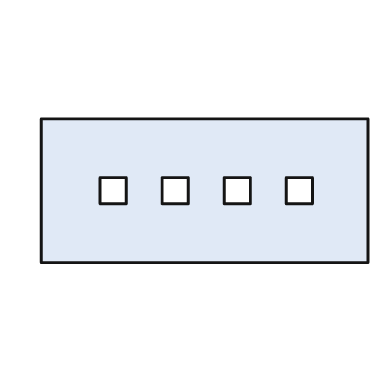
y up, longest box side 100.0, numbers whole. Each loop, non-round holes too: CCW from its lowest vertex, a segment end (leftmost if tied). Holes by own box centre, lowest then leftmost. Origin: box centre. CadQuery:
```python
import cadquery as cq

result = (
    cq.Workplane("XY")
    .moveTo(-50.0, -22.0)
    .lineTo(50.0, -22.0)
    .lineTo(50.0, 22.0)
    .lineTo(-50.0, 22.0)
    .close()
    .moveTo(-32.0, -4.0)
    .lineTo(-24.0, -4.0)
    .lineTo(-24.0, 4.0)
    .lineTo(-32.0, 4.0)
    .close()
    .moveTo(-13.0, -4.0)
    .lineTo(-5.0, -4.0)
    .lineTo(-5.0, 4.0)
    .lineTo(-13.0, 4.0)
    .close()
    .moveTo(6.0, -4.0)
    .lineTo(14.0, -4.0)
    .lineTo(14.0, 4.0)
    .lineTo(6.0, 4.0)
    .close()
    .moveTo(25.0, -4.0)
    .lineTo(33.0, -4.0)
    .lineTo(33.0, 4.0)
    .lineTo(25.0, 4.0)
    .close()
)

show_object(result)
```